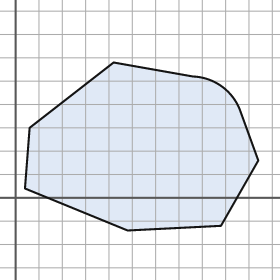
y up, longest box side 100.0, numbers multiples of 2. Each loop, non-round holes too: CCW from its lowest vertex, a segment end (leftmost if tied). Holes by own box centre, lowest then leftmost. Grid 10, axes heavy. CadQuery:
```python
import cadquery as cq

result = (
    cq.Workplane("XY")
    .moveTo(48.0, -14.0)
    .lineTo(88.0, -12.0)
    .lineTo(104.0, 16.0)
    .lineTo(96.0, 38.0)
    .threePointArc((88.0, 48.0), (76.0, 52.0))
    .lineTo(42.0, 58.0)
    .lineTo(6.0, 30.0)
    .lineTo(4.0, 4.0)
    .close()
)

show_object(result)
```